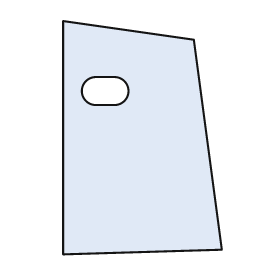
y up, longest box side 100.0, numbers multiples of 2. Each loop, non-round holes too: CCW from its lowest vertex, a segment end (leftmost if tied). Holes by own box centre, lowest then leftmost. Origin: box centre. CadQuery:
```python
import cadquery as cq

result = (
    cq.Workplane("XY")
    .moveTo(-34.0, -50.0)
    .lineTo(34.0, -48.0)
    .lineTo(22.0, 42.0)
    .lineTo(-34.0, 50.0)
    .close()
    .moveTo(-20.0, 14.0)
    .lineTo(-12.0, 14.0)
    .threePointArc((-6.0, 20.0), (-12.0, 26.0))
    .lineTo(-20.0, 26.0)
    .threePointArc((-26.0, 20.0), (-20.0, 14.0))
    .close()
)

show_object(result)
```